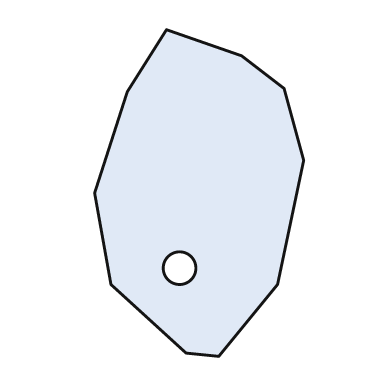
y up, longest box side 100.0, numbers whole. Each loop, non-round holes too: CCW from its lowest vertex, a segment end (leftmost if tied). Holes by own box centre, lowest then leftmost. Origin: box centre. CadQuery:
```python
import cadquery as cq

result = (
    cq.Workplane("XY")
    .moveTo(6.0, -50.0)
    .lineTo(24.0, -28.0)
    .lineTo(32.0, 10.0)
    .lineTo(26.0, 32.0)
    .lineTo(13.0, 42.0)
    .lineTo(-10.0, 50.0)
    .lineTo(-22.0, 31.0)
    .lineTo(-32.0, 0.0)
    .lineTo(-27.0, -28.0)
    .lineTo(-4.0, -49.0)
    .close()
    .moveTo(-6.0, -23.0)
    .circle(5.0)
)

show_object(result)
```